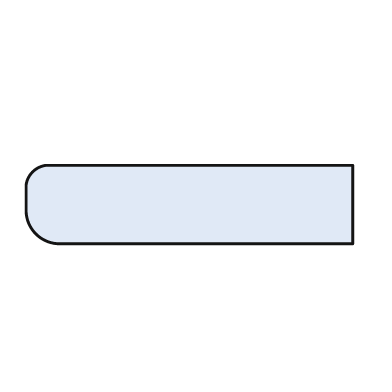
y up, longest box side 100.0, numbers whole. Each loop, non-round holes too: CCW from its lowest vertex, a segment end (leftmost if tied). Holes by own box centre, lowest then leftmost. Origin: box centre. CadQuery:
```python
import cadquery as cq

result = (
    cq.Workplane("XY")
    .moveTo(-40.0, -12.0)
    .lineTo(50.0, -12.0)
    .lineTo(50.0, 12.0)
    .lineTo(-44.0, 12.0)
    .threePointArc((-48.0, 10.0), (-50.0, 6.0))
    .lineTo(-50.0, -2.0)
    .threePointArc((-47.0, -9.0), (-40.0, -12.0))
    .close()
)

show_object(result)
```